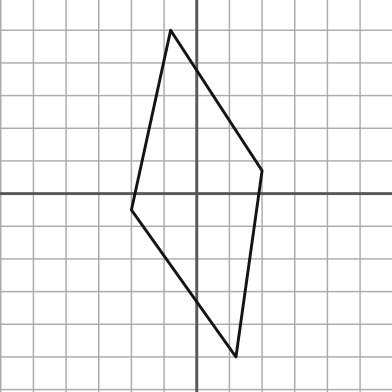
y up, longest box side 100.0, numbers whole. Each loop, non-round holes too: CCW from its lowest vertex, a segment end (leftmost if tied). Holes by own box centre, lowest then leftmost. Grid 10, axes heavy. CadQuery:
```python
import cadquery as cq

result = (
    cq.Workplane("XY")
    .moveTo(12.0, -50.0)
    .lineTo(20.0, 7.0)
    .lineTo(-8.0, 50.0)
    .lineTo(-20.0, -5.0)
    .close()
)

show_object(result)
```